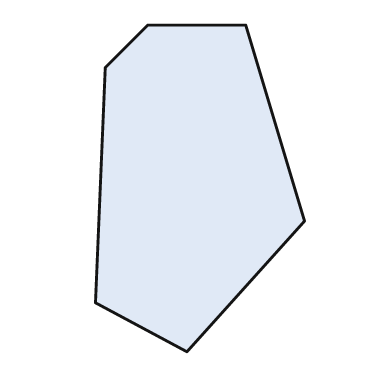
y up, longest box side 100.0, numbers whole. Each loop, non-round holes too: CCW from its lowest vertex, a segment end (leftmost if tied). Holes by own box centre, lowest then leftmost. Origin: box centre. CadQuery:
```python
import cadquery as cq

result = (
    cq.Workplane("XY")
    .moveTo(-4.0, -50.0)
    .lineTo(32.0, -10.0)
    .lineTo(14.0, 50.0)
    .lineTo(-16.0, 50.0)
    .lineTo(-29.0, 37.0)
    .lineTo(-32.0, -35.0)
    .close()
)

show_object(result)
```